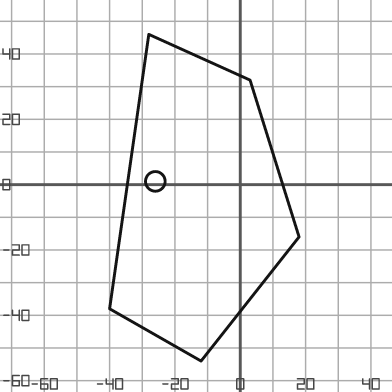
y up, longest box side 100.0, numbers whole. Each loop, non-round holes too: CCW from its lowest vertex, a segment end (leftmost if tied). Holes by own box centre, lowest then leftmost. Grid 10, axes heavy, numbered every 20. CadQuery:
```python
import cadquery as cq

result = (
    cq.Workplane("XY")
    .moveTo(-12.0, -54.0)
    .lineTo(18.0, -16.0)
    .lineTo(3.0, 32.0)
    .lineTo(-28.0, 46.0)
    .lineTo(-40.0, -38.0)
    .close()
    .moveTo(-26.0, 1.0)
    .circle(3.0)
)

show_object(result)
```